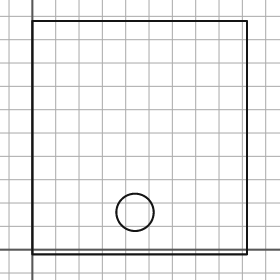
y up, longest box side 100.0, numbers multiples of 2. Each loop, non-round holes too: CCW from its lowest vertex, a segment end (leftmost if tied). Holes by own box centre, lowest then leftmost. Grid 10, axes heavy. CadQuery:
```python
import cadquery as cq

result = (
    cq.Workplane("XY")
    .moveTo(0.0, -2.0)
    .lineTo(92.0, -2.0)
    .lineTo(92.0, 98.0)
    .lineTo(0.0, 98.0)
    .close()
    .moveTo(44.0, 16.0)
    .circle(8.0)
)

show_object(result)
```